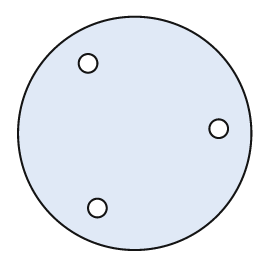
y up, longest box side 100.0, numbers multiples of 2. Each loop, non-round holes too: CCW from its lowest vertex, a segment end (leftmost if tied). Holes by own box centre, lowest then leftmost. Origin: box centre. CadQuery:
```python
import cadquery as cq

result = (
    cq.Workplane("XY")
    .moveTo(0.0, 0.0)
    .circle(50.0)
    .moveTo(-16.0, -32.0)
    .circle(4.0)
    .moveTo(36.0, 2.0)
    .circle(4.0)
    .moveTo(-20.0, 30.0)
    .circle(4.0)
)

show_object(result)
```